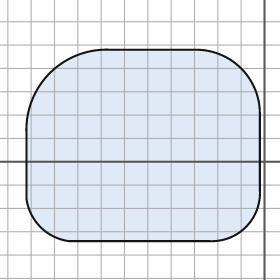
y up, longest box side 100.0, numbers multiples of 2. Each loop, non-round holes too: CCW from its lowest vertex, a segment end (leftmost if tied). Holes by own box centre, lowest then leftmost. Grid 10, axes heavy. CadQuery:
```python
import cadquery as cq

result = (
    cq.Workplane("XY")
    .moveTo(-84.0, -34.0)
    .lineTo(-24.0, -34.0)
    .threePointArc((-8.0, -28.0), (-2.0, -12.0))
    .lineTo(-2.0, 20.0)
    .threePointArc((-10.0, 40.0), (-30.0, 48.0))
    .lineTo(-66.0, 48.0)
    .threePointArc((-92.0, 38.0), (-102.0, 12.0))
    .lineTo(-102.0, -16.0)
    .threePointArc((-96.0, -28.0), (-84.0, -34.0))
    .close()
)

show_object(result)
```